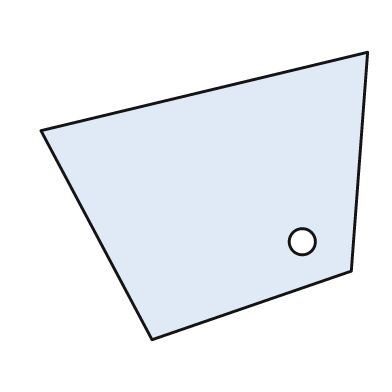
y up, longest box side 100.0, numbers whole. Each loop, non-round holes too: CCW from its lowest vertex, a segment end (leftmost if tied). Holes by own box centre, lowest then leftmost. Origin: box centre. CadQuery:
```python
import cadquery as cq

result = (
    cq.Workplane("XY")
    .moveTo(-16.0, -44.0)
    .lineTo(45.0, -23.0)
    .lineTo(50.0, 44.0)
    .lineTo(-50.0, 20.0)
    .close()
    .moveTo(30.0, -14.0)
    .circle(4.0)
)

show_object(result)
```